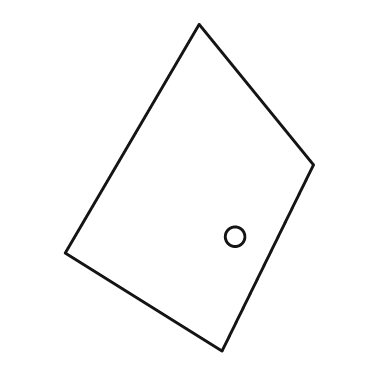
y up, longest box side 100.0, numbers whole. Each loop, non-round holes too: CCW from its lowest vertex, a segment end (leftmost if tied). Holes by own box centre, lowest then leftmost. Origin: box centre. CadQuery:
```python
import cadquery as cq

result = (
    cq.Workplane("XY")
    .moveTo(10.0, -50.0)
    .lineTo(38.0, 7.0)
    .lineTo(3.0, 50.0)
    .lineTo(-38.0, -20.0)
    .close()
    .moveTo(14.0, -15.0)
    .circle(3.0)
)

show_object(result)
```